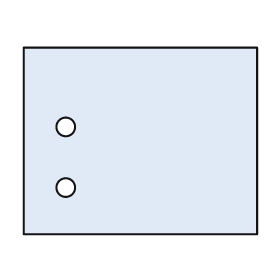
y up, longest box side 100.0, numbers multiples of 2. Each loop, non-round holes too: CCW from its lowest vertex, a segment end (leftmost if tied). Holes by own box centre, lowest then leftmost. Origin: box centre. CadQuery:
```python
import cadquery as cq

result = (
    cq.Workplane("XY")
    .moveTo(-50.0, -40.0)
    .lineTo(50.0, -40.0)
    .lineTo(50.0, 40.0)
    .lineTo(-50.0, 40.0)
    .close()
    .moveTo(-32.0, -20.0)
    .circle(4.0)
    .moveTo(-32.0, 6.0)
    .circle(4.0)
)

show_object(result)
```